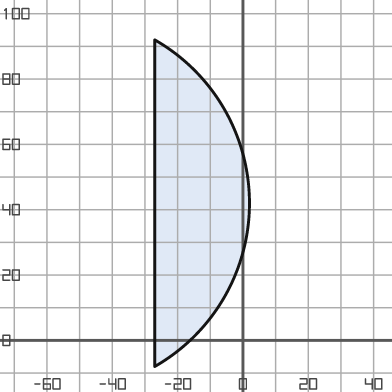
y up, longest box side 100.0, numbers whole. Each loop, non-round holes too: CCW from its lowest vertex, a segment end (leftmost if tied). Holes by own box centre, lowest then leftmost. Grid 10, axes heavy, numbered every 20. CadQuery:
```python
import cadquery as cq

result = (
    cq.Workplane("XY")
    .moveTo(-27.0, -8.0)
    .threePointArc((2.0, 42.0), (-27.0, 92.0))
    .close()
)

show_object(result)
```